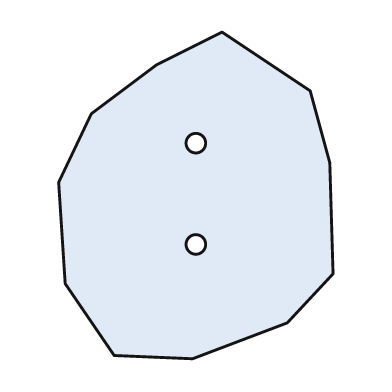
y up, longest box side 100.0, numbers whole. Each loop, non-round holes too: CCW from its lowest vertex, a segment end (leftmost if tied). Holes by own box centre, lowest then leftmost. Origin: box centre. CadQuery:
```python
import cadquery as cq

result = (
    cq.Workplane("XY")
    .moveTo(-1.0, -50.0)
    .lineTo(28.0, -39.0)
    .lineTo(42.0, -24.0)
    .lineTo(41.0, 10.0)
    .lineTo(35.0, 32.0)
    .lineTo(8.0, 50.0)
    .lineTo(-12.0, 40.0)
    .lineTo(-32.0, 25.0)
    .lineTo(-42.0, 4.0)
    .lineTo(-40.0, -27.0)
    .lineTo(-25.0, -49.0)
    .close()
    .moveTo(0.0, -15.0)
    .circle(3.0)
    .moveTo(0.0, 16.0)
    .circle(3.0)
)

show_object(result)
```